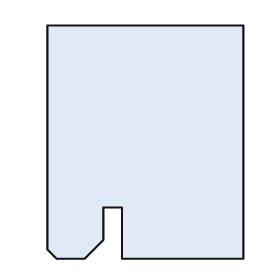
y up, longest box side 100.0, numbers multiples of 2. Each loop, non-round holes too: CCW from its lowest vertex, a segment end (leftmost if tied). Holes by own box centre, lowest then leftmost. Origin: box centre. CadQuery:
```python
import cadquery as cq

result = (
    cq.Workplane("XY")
    .moveTo(-38.0, -50.0)
    .lineTo(-26.0, -50.0)
    .lineTo(-18.0, -42.0)
    .lineTo(-18.0, -28.0)
    .lineTo(-10.0, -28.0)
    .lineTo(-10.0, -50.0)
    .lineTo(42.0, -50.0)
    .lineTo(42.0, 50.0)
    .lineTo(-42.0, 50.0)
    .lineTo(-42.0, -46.0)
    .close()
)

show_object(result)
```